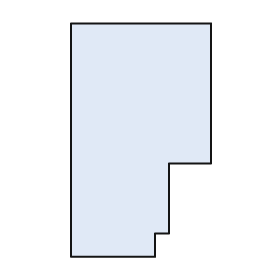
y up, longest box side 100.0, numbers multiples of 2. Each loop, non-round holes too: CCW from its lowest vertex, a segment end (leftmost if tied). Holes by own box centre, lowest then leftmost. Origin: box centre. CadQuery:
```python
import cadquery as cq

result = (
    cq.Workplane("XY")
    .moveTo(-30.0, -50.0)
    .lineTo(6.0, -50.0)
    .lineTo(6.0, -40.0)
    .lineTo(12.0, -40.0)
    .lineTo(12.0, -10.0)
    .lineTo(30.0, -10.0)
    .lineTo(30.0, 50.0)
    .lineTo(-30.0, 50.0)
    .close()
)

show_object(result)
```